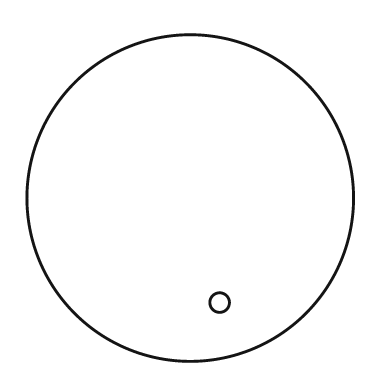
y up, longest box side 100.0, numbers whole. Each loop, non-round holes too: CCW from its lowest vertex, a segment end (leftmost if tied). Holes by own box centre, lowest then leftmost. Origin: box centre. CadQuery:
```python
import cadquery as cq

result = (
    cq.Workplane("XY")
    .moveTo(0.0, 0.0)
    .circle(50.0)
    .moveTo(9.0, -32.0)
    .circle(3.0)
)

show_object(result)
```